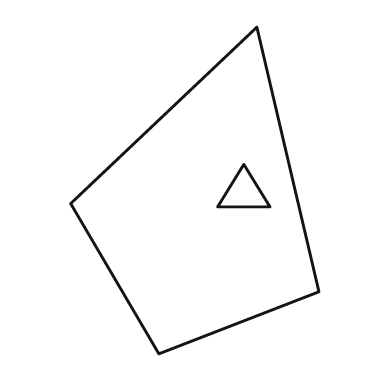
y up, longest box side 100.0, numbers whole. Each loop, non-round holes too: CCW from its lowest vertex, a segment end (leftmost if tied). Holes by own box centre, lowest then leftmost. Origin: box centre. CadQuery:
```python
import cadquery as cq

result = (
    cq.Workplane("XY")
    .moveTo(-11.0, -50.0)
    .lineTo(38.0, -31.0)
    .lineTo(19.0, 50.0)
    .lineTo(-38.0, -4.0)
    .close()
    .moveTo(7.0, -5.0)
    .lineTo(23.0, -5.0)
    .lineTo(15.0, 8.0)
    .close()
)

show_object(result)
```